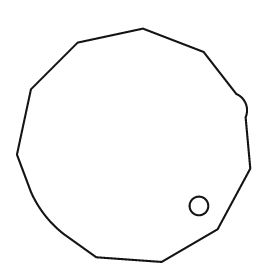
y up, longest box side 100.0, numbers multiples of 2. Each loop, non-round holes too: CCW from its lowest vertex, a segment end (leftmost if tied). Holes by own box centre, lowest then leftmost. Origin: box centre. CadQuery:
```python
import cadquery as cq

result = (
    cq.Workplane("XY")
    .moveTo(12.0, -50.0)
    .lineTo(36.0, -36.0)
    .lineTo(50.0, -10.0)
    .lineTo(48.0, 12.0)
    .threePointArc((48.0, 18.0), (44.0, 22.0))
    .lineTo(30.0, 40.0)
    .lineTo(4.0, 50.0)
    .lineTo(-24.0, 44.0)
    .lineTo(-44.0, 24.0)
    .lineTo(-50.0, -4.0)
    .lineTo(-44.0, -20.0)
    .threePointArc((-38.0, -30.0), (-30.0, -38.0))
    .lineTo(-16.0, -48.0)
    .close()
    .moveTo(28.0, -26.0)
    .circle(4.0)
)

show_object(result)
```